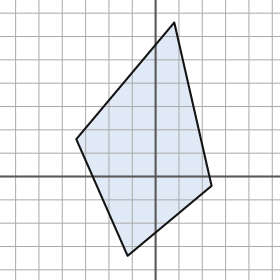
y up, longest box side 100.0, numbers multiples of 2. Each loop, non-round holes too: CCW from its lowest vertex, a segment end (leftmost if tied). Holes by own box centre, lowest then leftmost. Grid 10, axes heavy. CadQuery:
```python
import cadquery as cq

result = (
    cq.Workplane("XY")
    .moveTo(-12.0, -34.0)
    .lineTo(24.0, -4.0)
    .lineTo(8.0, 66.0)
    .lineTo(-34.0, 16.0)
    .close()
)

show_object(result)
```